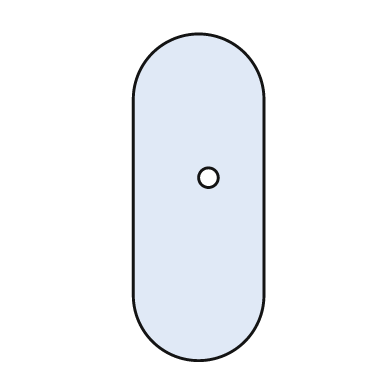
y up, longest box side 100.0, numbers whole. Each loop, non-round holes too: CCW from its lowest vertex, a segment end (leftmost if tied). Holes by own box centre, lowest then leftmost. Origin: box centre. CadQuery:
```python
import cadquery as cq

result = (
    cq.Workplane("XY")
    .moveTo(-20.0, -30.0)
    .threePointArc((0.0, -50.0), (20.0, -30.0))
    .lineTo(20.0, 30.0)
    .threePointArc((0.0, 50.0), (-20.0, 30.0))
    .close()
    .moveTo(3.0, 6.0)
    .circle(3.0)
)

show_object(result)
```